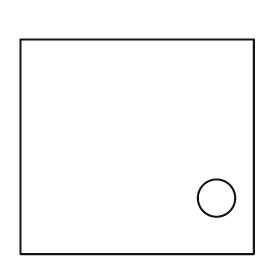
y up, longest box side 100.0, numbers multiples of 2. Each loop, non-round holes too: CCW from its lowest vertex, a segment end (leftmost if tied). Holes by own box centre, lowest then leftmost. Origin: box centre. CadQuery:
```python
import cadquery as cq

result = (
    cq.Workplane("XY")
    .moveTo(-50.0, -46.0)
    .lineTo(50.0, -46.0)
    .lineTo(50.0, 46.0)
    .lineTo(-50.0, 46.0)
    .close()
    .moveTo(34.0, -22.0)
    .circle(8.0)
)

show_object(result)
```